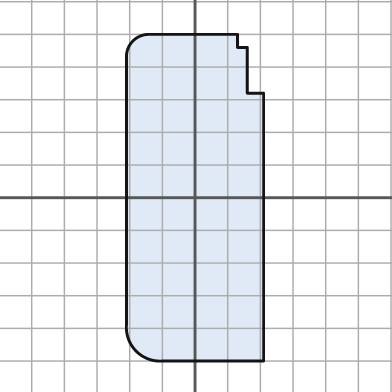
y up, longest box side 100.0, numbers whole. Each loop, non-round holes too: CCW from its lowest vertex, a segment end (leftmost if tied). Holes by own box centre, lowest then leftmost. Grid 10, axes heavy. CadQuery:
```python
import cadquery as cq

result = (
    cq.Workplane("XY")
    .moveTo(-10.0, -50.0)
    .lineTo(21.0, -50.0)
    .lineTo(21.0, 32.0)
    .lineTo(16.0, 32.0)
    .lineTo(16.0, 46.0)
    .lineTo(13.0, 46.0)
    .lineTo(13.0, 50.0)
    .lineTo(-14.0, 50.0)
    .threePointArc((-19.0, 48.0), (-21.0, 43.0))
    .lineTo(-21.0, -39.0)
    .threePointArc((-18.0, -47.0), (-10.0, -50.0))
    .close()
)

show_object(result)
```